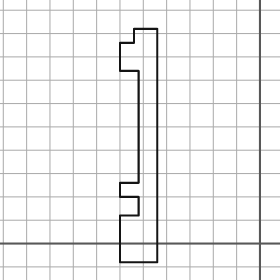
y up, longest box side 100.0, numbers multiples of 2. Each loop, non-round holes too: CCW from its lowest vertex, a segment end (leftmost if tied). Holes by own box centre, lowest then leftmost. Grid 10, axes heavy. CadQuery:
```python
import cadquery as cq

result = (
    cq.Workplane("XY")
    .moveTo(-60.0, -8.0)
    .lineTo(-44.0, -8.0)
    .lineTo(-44.0, 92.0)
    .lineTo(-54.0, 92.0)
    .lineTo(-54.0, 86.0)
    .lineTo(-60.0, 86.0)
    .lineTo(-60.0, 74.0)
    .lineTo(-52.0, 74.0)
    .lineTo(-52.0, 26.0)
    .lineTo(-60.0, 26.0)
    .lineTo(-60.0, 20.0)
    .lineTo(-52.0, 20.0)
    .lineTo(-52.0, 12.0)
    .lineTo(-60.0, 12.0)
    .close()
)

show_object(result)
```